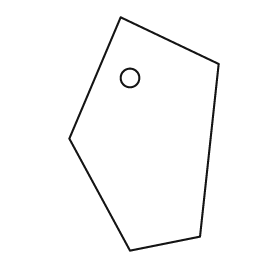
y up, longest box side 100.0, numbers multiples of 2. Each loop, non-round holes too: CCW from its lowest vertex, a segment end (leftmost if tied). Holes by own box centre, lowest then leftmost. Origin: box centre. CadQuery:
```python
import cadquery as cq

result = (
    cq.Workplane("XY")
    .moveTo(-6.0, -50.0)
    .lineTo(24.0, -44.0)
    .lineTo(32.0, 30.0)
    .lineTo(-10.0, 50.0)
    .lineTo(-32.0, -2.0)
    .close()
    .moveTo(-6.0, 24.0)
    .circle(4.0)
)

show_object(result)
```